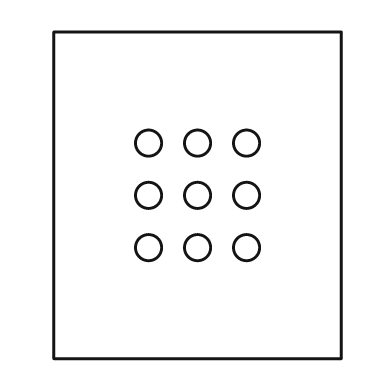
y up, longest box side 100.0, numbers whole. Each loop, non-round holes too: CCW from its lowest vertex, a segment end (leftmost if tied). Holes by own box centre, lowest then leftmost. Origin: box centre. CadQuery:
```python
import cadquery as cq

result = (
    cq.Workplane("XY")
    .moveTo(-44.0, -50.0)
    .lineTo(44.0, -50.0)
    .lineTo(44.0, 50.0)
    .lineTo(-44.0, 50.0)
    .close()
    .moveTo(-15.0, -16.0)
    .circle(4.0)
    .moveTo(0.0, -16.0)
    .circle(4.0)
    .moveTo(15.0, -16.0)
    .circle(4.0)
    .moveTo(-15.0, 0.0)
    .circle(4.0)
    .moveTo(0.0, 0.0)
    .circle(4.0)
    .moveTo(15.0, 0.0)
    .circle(4.0)
    .moveTo(-15.0, 16.0)
    .circle(4.0)
    .moveTo(0.0, 16.0)
    .circle(4.0)
    .moveTo(15.0, 16.0)
    .circle(4.0)
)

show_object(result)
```